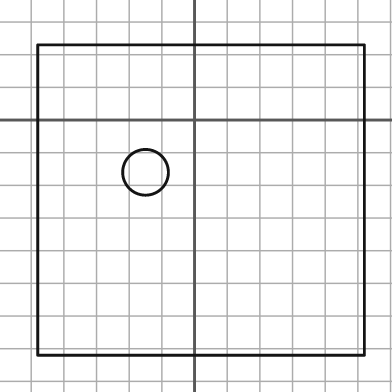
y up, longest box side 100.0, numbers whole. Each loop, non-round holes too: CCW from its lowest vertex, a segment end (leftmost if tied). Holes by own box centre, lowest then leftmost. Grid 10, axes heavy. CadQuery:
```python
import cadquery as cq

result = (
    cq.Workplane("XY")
    .moveTo(-48.0, -72.0)
    .lineTo(52.0, -72.0)
    .lineTo(52.0, 23.0)
    .lineTo(-48.0, 23.0)
    .close()
    .moveTo(-15.0, -16.0)
    .circle(7.0)
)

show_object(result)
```